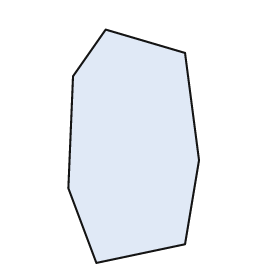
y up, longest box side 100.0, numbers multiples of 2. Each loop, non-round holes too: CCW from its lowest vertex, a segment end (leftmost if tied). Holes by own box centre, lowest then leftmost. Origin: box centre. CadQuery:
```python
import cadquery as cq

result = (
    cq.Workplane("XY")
    .moveTo(-16.0, -50.0)
    .lineTo(22.0, -42.0)
    .lineTo(28.0, -6.0)
    .lineTo(22.0, 40.0)
    .lineTo(-12.0, 50.0)
    .lineTo(-26.0, 30.0)
    .lineTo(-28.0, -18.0)
    .close()
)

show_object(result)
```